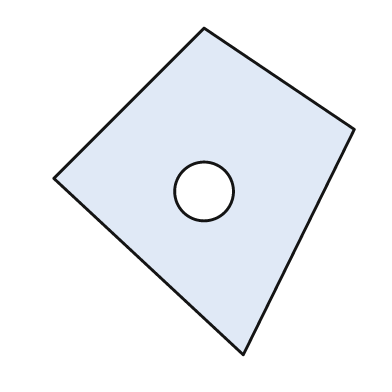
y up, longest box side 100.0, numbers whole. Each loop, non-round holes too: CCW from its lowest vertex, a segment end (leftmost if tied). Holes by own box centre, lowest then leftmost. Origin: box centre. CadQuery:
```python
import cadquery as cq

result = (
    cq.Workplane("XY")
    .moveTo(12.0, -50.0)
    .lineTo(46.0, 19.0)
    .lineTo(0.0, 50.0)
    .lineTo(-46.0, 4.0)
    .close()
    .moveTo(0.0, 0.0)
    .circle(9.0)
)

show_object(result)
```